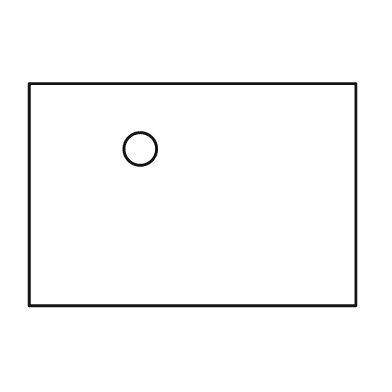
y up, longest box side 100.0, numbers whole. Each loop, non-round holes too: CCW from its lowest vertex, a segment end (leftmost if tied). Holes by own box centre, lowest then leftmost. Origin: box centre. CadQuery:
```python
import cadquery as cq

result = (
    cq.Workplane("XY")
    .moveTo(-50.0, -34.0)
    .lineTo(50.0, -34.0)
    .lineTo(50.0, 34.0)
    .lineTo(-50.0, 34.0)
    .close()
    .moveTo(-16.0, 14.0)
    .circle(5.0)
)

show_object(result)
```